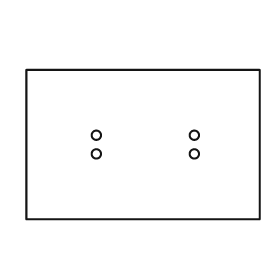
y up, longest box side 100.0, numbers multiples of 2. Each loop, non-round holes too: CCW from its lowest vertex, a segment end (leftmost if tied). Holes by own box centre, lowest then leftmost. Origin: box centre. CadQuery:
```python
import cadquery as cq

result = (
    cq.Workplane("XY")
    .moveTo(-50.0, -32.0)
    .lineTo(50.0, -32.0)
    .lineTo(50.0, 32.0)
    .lineTo(-50.0, 32.0)
    .close()
    .moveTo(-20.0, -4.0)
    .circle(2.0)
    .moveTo(22.0, -4.0)
    .circle(2.0)
    .moveTo(-20.0, 4.0)
    .circle(2.0)
    .moveTo(22.0, 4.0)
    .circle(2.0)
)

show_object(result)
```